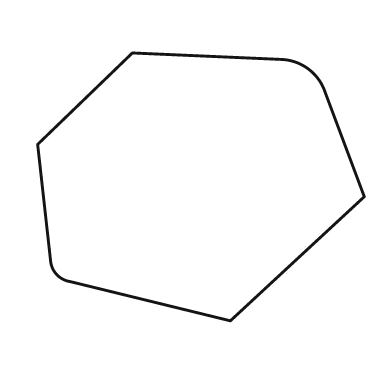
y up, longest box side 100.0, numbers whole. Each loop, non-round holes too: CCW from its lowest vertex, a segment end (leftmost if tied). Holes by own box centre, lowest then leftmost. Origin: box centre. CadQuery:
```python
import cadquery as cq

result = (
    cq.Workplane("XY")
    .moveTo(9.0, -41.0)
    .lineTo(50.0, -3.0)
    .lineTo(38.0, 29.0)
    .threePointArc((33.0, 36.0), (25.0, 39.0))
    .lineTo(-21.0, 41.0)
    .lineTo(-50.0, 13.0)
    .lineTo(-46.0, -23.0)
    .threePointArc((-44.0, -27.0), (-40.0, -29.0))
    .close()
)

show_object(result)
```